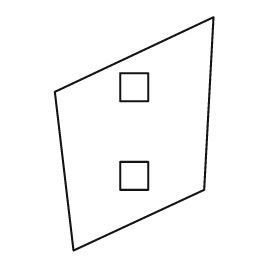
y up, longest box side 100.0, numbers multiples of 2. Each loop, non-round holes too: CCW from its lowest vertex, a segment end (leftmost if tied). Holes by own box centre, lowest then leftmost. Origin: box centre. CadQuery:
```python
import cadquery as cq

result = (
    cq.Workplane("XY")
    .moveTo(-26.0, -50.0)
    .lineTo(30.0, -24.0)
    .lineTo(34.0, 50.0)
    .lineTo(-34.0, 18.0)
    .close()
    .moveTo(-6.0, -24.0)
    .lineTo(6.0, -24.0)
    .lineTo(6.0, -12.0)
    .lineTo(-6.0, -12.0)
    .close()
    .moveTo(-6.0, 14.0)
    .lineTo(6.0, 14.0)
    .lineTo(6.0, 26.0)
    .lineTo(-6.0, 26.0)
    .close()
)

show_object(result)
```